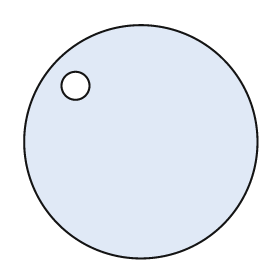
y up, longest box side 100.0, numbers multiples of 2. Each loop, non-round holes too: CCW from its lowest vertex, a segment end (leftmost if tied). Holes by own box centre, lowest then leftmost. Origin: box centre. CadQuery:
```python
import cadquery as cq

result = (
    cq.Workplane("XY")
    .moveTo(0.0, 0.0)
    .circle(50.0)
    .moveTo(-28.0, 24.0)
    .circle(6.0)
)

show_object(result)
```